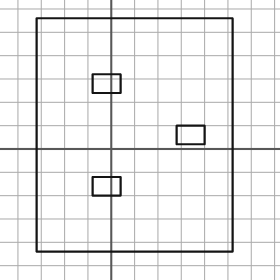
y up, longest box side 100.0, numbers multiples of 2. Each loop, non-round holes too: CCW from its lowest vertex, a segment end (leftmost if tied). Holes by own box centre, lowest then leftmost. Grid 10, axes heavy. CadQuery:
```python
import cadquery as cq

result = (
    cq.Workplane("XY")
    .moveTo(-32.0, -44.0)
    .lineTo(52.0, -44.0)
    .lineTo(52.0, 56.0)
    .lineTo(-32.0, 56.0)
    .close()
    .moveTo(-8.0, -20.0)
    .lineTo(4.0, -20.0)
    .lineTo(4.0, -12.0)
    .lineTo(-8.0, -12.0)
    .close()
    .moveTo(28.0, 2.0)
    .lineTo(40.0, 2.0)
    .lineTo(40.0, 10.0)
    .lineTo(28.0, 10.0)
    .close()
    .moveTo(-8.0, 24.0)
    .lineTo(4.0, 24.0)
    .lineTo(4.0, 32.0)
    .lineTo(-8.0, 32.0)
    .close()
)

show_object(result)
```